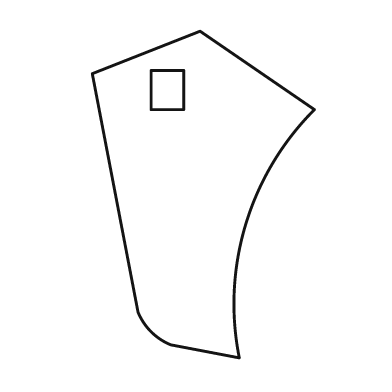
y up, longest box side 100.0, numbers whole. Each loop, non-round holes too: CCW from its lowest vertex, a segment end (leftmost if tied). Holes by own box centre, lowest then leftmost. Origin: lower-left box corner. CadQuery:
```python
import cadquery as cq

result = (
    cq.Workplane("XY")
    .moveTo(45.0, 0.0)
    .threePointArc((47.0, 41.0), (68.0, 76.0))
    .lineTo(33.0, 100.0)
    .lineTo(0.0, 87.0)
    .lineTo(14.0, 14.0)
    .threePointArc((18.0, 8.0), (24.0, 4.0))
    .close()
    .moveTo(18.0, 76.0)
    .lineTo(28.0, 76.0)
    .lineTo(28.0, 88.0)
    .lineTo(18.0, 88.0)
    .close()
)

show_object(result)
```